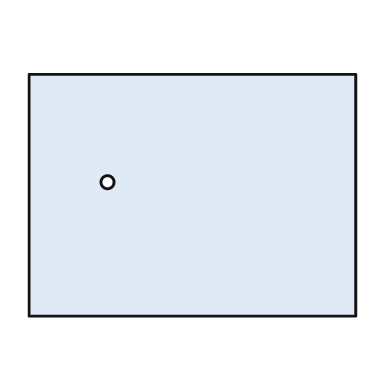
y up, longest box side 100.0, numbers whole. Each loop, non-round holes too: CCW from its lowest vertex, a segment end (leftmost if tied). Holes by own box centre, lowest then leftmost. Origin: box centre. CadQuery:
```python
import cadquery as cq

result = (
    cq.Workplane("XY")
    .moveTo(-50.0, -37.0)
    .lineTo(50.0, -37.0)
    .lineTo(50.0, 37.0)
    .lineTo(-50.0, 37.0)
    .close()
    .moveTo(-26.0, 4.0)
    .circle(2.0)
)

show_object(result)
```